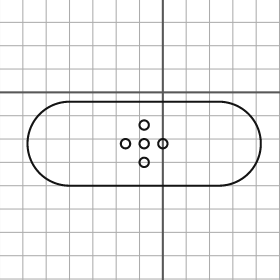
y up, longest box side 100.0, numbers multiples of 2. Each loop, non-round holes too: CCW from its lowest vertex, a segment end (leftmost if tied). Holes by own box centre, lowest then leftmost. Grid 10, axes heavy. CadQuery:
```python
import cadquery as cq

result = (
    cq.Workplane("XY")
    .moveTo(-40.0, -40.0)
    .lineTo(24.0, -40.0)
    .threePointArc((42.0, -22.0), (24.0, -4.0))
    .lineTo(-40.0, -4.0)
    .threePointArc((-58.0, -22.0), (-40.0, -40.0))
    .close()
    .moveTo(-8.0, -30.0)
    .circle(2.0)
    .moveTo(-16.0, -22.0)
    .circle(2.0)
    .moveTo(-8.0, -22.0)
    .circle(2.0)
    .moveTo(0.0, -22.0)
    .circle(2.0)
    .moveTo(-8.0, -14.0)
    .circle(2.0)
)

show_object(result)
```